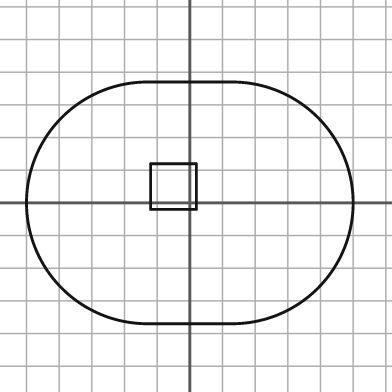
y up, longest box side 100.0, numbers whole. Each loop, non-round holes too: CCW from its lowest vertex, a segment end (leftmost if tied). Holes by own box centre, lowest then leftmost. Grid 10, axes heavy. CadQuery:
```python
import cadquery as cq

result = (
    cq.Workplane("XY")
    .moveTo(-13.0, -37.0)
    .lineTo(13.0, -37.0)
    .threePointArc((50.0, 0.0), (13.0, 37.0))
    .lineTo(-13.0, 37.0)
    .threePointArc((-50.0, 0.0), (-13.0, -37.0))
    .close()
    .moveTo(-12.0, -2.0)
    .lineTo(2.0, -2.0)
    .lineTo(2.0, 12.0)
    .lineTo(-12.0, 12.0)
    .close()
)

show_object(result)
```